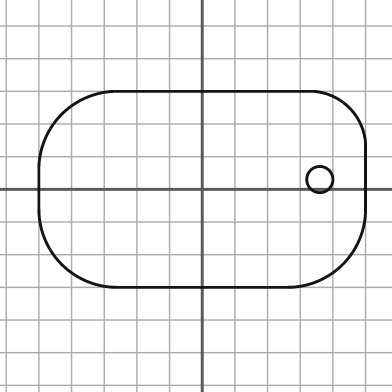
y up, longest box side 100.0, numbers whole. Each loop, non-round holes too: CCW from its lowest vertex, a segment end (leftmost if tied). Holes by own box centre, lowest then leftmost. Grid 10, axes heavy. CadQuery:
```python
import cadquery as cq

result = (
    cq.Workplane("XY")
    .moveTo(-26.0, -30.0)
    .lineTo(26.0, -30.0)
    .threePointArc((43.0, -23.0), (50.0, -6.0))
    .lineTo(50.0, 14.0)
    .threePointArc((45.0, 25.0), (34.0, 30.0))
    .lineTo(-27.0, 30.0)
    .threePointArc((-43.0, 23.0), (-50.0, 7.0))
    .lineTo(-50.0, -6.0)
    .threePointArc((-43.0, -23.0), (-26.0, -30.0))
    .close()
    .moveTo(36.0, 3.0)
    .circle(4.0)
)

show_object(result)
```